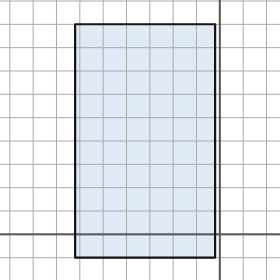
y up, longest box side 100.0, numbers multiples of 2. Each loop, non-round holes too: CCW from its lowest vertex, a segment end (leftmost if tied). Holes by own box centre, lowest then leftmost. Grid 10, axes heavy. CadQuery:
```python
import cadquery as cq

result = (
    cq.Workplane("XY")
    .moveTo(-62.0, -10.0)
    .lineTo(-2.0, -10.0)
    .lineTo(-2.0, 90.0)
    .lineTo(-62.0, 90.0)
    .close()
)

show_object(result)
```